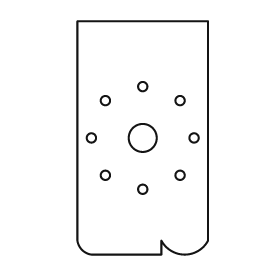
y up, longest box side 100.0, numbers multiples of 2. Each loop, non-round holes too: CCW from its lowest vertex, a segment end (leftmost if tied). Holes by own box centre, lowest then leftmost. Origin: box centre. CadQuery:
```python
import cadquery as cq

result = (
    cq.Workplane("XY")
    .moveTo(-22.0, -50.0)
    .lineTo(8.0, -50.0)
    .lineTo(8.0, -44.0)
    .threePointArc((18.0, -50.0), (28.0, -44.0))
    .lineTo(28.0, 50.0)
    .lineTo(-28.0, 50.0)
    .lineTo(-28.0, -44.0)
    .threePointArc((-26.0, -48.0), (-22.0, -50.0))
    .close()
    .moveTo(0.0, -22.0)
    .circle(2.0)
    .moveTo(-16.0, -16.0)
    .circle(2.0)
    .moveTo(16.0, -16.0)
    .circle(2.0)
    .moveTo(-22.0, 0.0)
    .circle(2.0)
    .moveTo(0.0, 0.0)
    .circle(6.0)
    .moveTo(22.0, 0.0)
    .circle(2.0)
    .moveTo(-16.0, 16.0)
    .circle(2.0)
    .moveTo(16.0, 16.0)
    .circle(2.0)
    .moveTo(0.0, 22.0)
    .circle(2.0)
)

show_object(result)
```